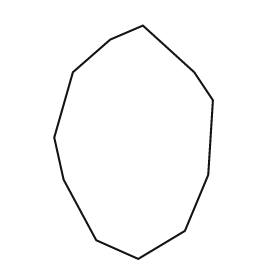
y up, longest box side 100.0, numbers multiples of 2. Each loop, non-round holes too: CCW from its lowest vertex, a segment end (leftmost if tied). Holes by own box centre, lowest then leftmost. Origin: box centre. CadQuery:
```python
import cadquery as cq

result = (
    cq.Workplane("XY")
    .moveTo(2.0, -50.0)
    .lineTo(22.0, -38.0)
    .lineTo(32.0, -14.0)
    .lineTo(34.0, 18.0)
    .lineTo(26.0, 30.0)
    .lineTo(4.0, 50.0)
    .lineTo(-10.0, 44.0)
    .lineTo(-26.0, 30.0)
    .lineTo(-34.0, 2.0)
    .lineTo(-30.0, -16.0)
    .lineTo(-16.0, -42.0)
    .close()
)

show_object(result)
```